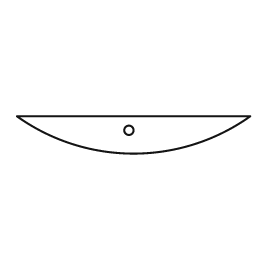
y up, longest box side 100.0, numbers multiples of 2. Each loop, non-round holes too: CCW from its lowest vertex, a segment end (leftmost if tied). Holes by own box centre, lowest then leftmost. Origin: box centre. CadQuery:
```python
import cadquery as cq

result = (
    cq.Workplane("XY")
    .moveTo(-50.0, 8.0)
    .threePointArc((0.0, -8.0), (50.0, 8.0))
    .close()
    .moveTo(-2.0, 2.0)
    .circle(2.0)
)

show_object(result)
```